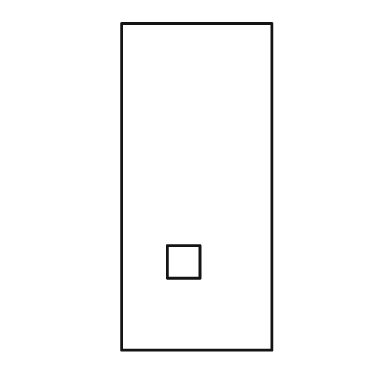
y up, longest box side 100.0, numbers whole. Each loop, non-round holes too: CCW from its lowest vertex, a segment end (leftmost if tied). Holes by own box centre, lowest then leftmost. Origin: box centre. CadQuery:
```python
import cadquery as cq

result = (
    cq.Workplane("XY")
    .moveTo(-23.0, -50.0)
    .lineTo(23.0, -50.0)
    .lineTo(23.0, 50.0)
    .lineTo(-23.0, 50.0)
    .close()
    .moveTo(-9.0, -28.0)
    .lineTo(1.0, -28.0)
    .lineTo(1.0, -18.0)
    .lineTo(-9.0, -18.0)
    .close()
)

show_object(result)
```